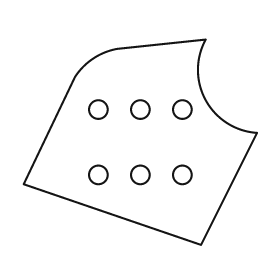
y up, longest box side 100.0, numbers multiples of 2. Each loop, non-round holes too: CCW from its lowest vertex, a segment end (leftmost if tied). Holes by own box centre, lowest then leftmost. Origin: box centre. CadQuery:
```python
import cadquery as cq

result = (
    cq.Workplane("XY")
    .moveTo(26.0, -44.0)
    .lineTo(50.0, 4.0)
    .threePointArc((28.0, 18.0), (28.0, 44.0))
    .lineTo(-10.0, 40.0)
    .threePointArc((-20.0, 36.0), (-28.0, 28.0))
    .lineTo(-50.0, -18.0)
    .close()
    .moveTo(-18.0, -14.0)
    .circle(4.0)
    .moveTo(0.0, -14.0)
    .circle(4.0)
    .moveTo(18.0, -14.0)
    .circle(4.0)
    .moveTo(-18.0, 14.0)
    .circle(4.0)
    .moveTo(0.0, 14.0)
    .circle(4.0)
    .moveTo(18.0, 14.0)
    .circle(4.0)
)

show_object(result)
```